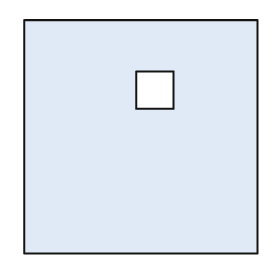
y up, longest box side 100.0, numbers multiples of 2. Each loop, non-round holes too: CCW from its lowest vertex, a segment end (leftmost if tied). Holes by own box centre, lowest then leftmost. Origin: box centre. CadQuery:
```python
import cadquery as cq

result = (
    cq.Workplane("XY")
    .moveTo(-50.0, -50.0)
    .lineTo(50.0, -50.0)
    .lineTo(50.0, 50.0)
    .lineTo(-50.0, 50.0)
    .close()
    .moveTo(-2.0, 12.0)
    .lineTo(14.0, 12.0)
    .lineTo(14.0, 28.0)
    .lineTo(-2.0, 28.0)
    .close()
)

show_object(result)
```